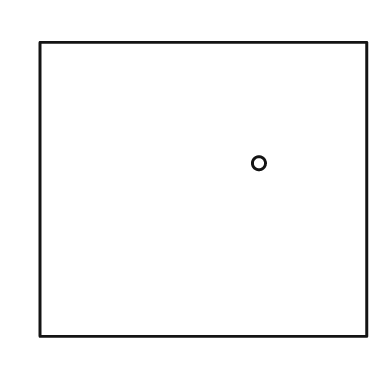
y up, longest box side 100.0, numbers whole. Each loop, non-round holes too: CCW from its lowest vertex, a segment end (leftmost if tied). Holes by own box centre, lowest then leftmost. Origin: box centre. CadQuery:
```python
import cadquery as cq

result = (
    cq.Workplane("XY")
    .moveTo(-50.0, -45.0)
    .lineTo(50.0, -45.0)
    .lineTo(50.0, 45.0)
    .lineTo(-50.0, 45.0)
    .close()
    .moveTo(17.0, 8.0)
    .circle(2.0)
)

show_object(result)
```